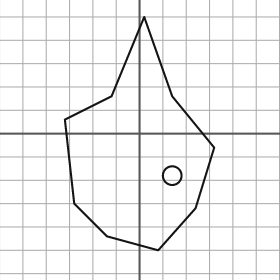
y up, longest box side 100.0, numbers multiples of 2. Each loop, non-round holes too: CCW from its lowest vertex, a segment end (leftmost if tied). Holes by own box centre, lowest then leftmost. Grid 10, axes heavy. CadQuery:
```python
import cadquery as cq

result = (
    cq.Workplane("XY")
    .moveTo(8.0, -50.0)
    .lineTo(24.0, -32.0)
    .lineTo(32.0, -6.0)
    .lineTo(14.0, 16.0)
    .lineTo(2.0, 50.0)
    .lineTo(-12.0, 16.0)
    .lineTo(-32.0, 6.0)
    .lineTo(-28.0, -30.0)
    .lineTo(-14.0, -44.0)
    .close()
    .moveTo(14.0, -18.0)
    .circle(4.0)
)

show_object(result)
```